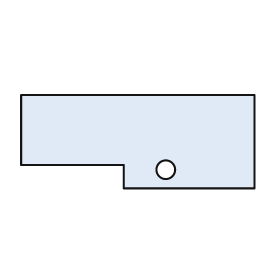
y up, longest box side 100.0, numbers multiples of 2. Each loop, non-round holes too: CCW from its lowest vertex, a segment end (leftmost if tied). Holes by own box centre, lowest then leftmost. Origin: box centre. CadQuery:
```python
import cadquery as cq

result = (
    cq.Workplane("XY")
    .moveTo(-6.0, -20.0)
    .lineTo(50.0, -20.0)
    .lineTo(50.0, 20.0)
    .lineTo(-50.0, 20.0)
    .lineTo(-50.0, -10.0)
    .lineTo(-6.0, -10.0)
    .close()
    .moveTo(12.0, -12.0)
    .circle(4.0)
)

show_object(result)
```